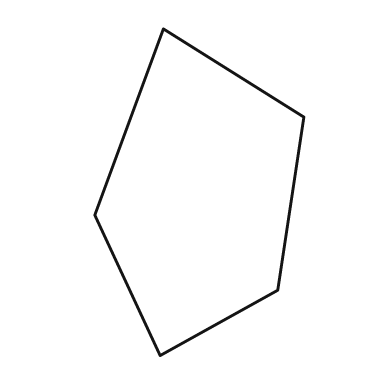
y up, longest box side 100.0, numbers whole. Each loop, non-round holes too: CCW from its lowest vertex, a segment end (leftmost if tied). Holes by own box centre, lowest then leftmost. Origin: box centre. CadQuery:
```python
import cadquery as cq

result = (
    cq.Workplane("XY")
    .moveTo(-12.0, -50.0)
    .lineTo(24.0, -30.0)
    .lineTo(32.0, 23.0)
    .lineTo(-11.0, 50.0)
    .lineTo(-32.0, -7.0)
    .close()
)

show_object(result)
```